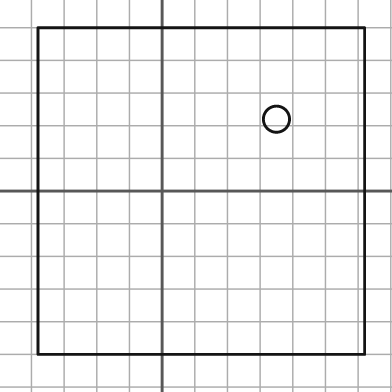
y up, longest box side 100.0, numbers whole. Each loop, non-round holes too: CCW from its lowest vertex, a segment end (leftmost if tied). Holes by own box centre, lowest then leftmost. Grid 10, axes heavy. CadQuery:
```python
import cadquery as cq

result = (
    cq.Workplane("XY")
    .moveTo(-38.0, -50.0)
    .lineTo(62.0, -50.0)
    .lineTo(62.0, 50.0)
    .lineTo(-38.0, 50.0)
    .close()
    .moveTo(35.0, 22.0)
    .circle(4.0)
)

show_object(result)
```